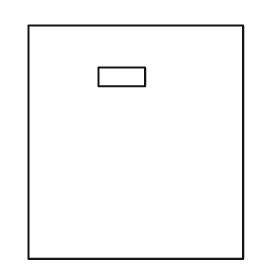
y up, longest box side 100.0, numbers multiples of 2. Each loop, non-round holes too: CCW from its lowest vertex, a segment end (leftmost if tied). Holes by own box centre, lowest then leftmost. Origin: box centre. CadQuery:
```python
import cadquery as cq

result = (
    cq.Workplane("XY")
    .moveTo(-46.0, -50.0)
    .lineTo(46.0, -50.0)
    .lineTo(46.0, 50.0)
    .lineTo(-46.0, 50.0)
    .close()
    .moveTo(-16.0, 24.0)
    .lineTo(4.0, 24.0)
    .lineTo(4.0, 32.0)
    .lineTo(-16.0, 32.0)
    .close()
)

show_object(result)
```